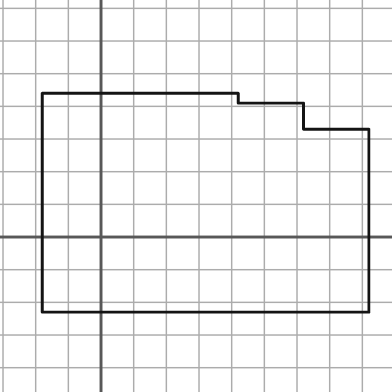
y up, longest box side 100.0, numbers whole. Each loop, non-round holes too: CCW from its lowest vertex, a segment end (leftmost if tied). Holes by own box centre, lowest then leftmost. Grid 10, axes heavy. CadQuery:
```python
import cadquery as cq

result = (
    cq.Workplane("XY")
    .moveTo(-18.0, -23.0)
    .lineTo(82.0, -23.0)
    .lineTo(82.0, 33.0)
    .lineTo(62.0, 33.0)
    .lineTo(62.0, 41.0)
    .lineTo(42.0, 41.0)
    .lineTo(42.0, 44.0)
    .lineTo(-18.0, 44.0)
    .close()
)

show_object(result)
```